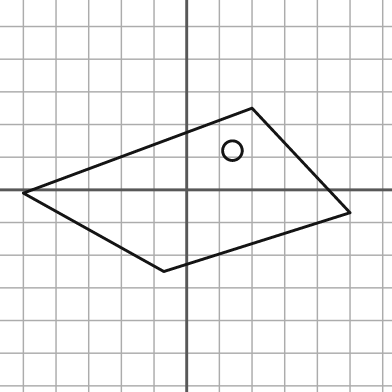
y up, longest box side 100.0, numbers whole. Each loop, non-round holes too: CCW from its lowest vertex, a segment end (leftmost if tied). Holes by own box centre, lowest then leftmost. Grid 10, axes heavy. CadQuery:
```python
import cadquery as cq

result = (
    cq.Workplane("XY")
    .moveTo(-7.0, -25.0)
    .lineTo(50.0, -7.0)
    .lineTo(20.0, 25.0)
    .lineTo(-50.0, -1.0)
    .close()
    .moveTo(14.0, 12.0)
    .circle(3.0)
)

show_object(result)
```